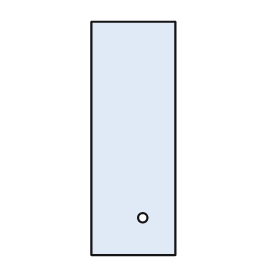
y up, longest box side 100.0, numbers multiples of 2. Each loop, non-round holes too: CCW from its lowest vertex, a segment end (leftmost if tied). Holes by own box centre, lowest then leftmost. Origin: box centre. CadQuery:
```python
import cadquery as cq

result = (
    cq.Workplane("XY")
    .moveTo(-18.0, -50.0)
    .lineTo(18.0, -50.0)
    .lineTo(18.0, 50.0)
    .lineTo(-18.0, 50.0)
    .close()
    .moveTo(4.0, -34.0)
    .circle(2.0)
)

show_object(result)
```